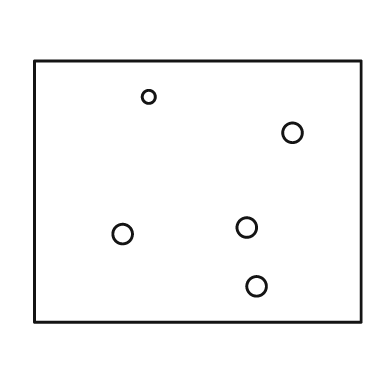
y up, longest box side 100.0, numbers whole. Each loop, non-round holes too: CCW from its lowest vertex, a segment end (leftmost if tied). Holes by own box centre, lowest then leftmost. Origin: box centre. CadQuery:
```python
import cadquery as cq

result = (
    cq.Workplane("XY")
    .moveTo(-50.0, -40.0)
    .lineTo(50.0, -40.0)
    .lineTo(50.0, 40.0)
    .lineTo(-50.0, 40.0)
    .close()
    .moveTo(18.0, -29.0)
    .circle(3.0)
    .moveTo(-23.0, -13.0)
    .circle(3.0)
    .moveTo(15.0, -11.0)
    .circle(3.0)
    .moveTo(29.0, 18.0)
    .circle(3.0)
    .moveTo(-15.0, 29.0)
    .circle(2.0)
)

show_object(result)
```